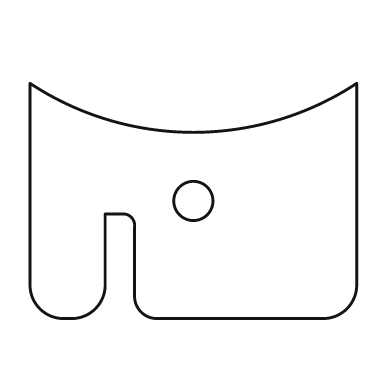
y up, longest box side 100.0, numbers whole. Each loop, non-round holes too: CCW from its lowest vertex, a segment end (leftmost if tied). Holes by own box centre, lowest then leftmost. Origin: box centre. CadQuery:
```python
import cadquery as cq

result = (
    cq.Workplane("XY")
    .moveTo(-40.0, -36.0)
    .lineTo(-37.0, -36.0)
    .threePointArc((-30.0, -33.0), (-27.0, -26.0))
    .lineTo(-27.0, -4.0)
    .lineTo(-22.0, -4.0)
    .threePointArc((-19.0, -5.0), (-18.0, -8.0))
    .lineTo(-18.0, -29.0)
    .threePointArc((-16.0, -34.0), (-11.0, -36.0))
    .lineTo(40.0, -36.0)
    .threePointArc((47.0, -33.0), (50.0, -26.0))
    .lineTo(50.0, 36.0)
    .threePointArc((0.0, 21.0), (-50.0, 36.0))
    .lineTo(-50.0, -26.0)
    .threePointArc((-47.0, -33.0), (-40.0, -36.0))
    .close()
    .moveTo(0.0, 0.0)
    .circle(6.0)
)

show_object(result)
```